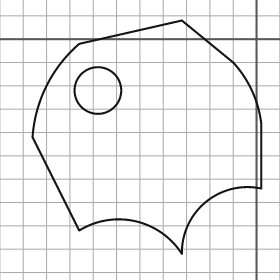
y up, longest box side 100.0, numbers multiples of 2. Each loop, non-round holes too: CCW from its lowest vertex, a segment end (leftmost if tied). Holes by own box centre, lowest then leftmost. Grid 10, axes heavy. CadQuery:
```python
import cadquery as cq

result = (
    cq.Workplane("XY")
    .moveTo(-32.0, -92.0)
    .threePointArc((-22.0, -70.0), (2.0, -64.0))
    .lineTo(2.0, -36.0)
    .threePointArc((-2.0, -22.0), (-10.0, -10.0))
    .lineTo(-32.0, 8.0)
    .lineTo(-76.0, -2.0)
    .threePointArc((-90.0, -20.0), (-96.0, -42.0))
    .lineTo(-76.0, -82.0)
    .threePointArc((-52.0, -78.0), (-32.0, -92.0))
    .close()
    .moveTo(-68.0, -22.0)
    .circle(10.0)
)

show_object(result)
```